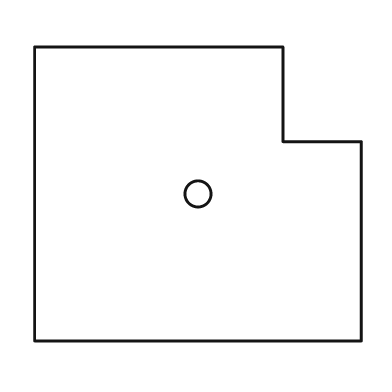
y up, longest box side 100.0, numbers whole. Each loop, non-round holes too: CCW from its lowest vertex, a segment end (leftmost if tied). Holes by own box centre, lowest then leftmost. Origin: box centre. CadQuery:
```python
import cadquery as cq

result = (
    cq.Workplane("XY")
    .moveTo(-50.0, -45.0)
    .lineTo(50.0, -45.0)
    .lineTo(50.0, 16.0)
    .lineTo(26.0, 16.0)
    .lineTo(26.0, 45.0)
    .lineTo(-50.0, 45.0)
    .close()
    .moveTo(0.0, 0.0)
    .circle(4.0)
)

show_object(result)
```